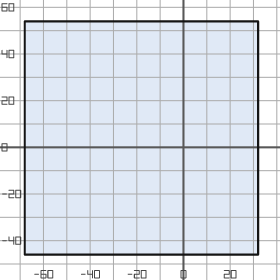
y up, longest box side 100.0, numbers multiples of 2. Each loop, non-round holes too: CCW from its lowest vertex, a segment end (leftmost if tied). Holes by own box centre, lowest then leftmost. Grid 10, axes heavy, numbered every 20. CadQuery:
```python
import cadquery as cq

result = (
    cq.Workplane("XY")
    .moveTo(-68.0, -46.0)
    .lineTo(32.0, -46.0)
    .lineTo(32.0, 54.0)
    .lineTo(-68.0, 54.0)
    .close()
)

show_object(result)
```